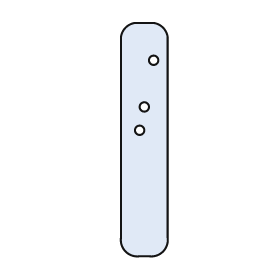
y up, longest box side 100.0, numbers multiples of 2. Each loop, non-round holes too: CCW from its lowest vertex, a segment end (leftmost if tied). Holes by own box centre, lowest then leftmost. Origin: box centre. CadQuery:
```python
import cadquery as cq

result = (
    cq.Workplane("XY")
    .moveTo(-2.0, -50.0)
    .lineTo(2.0, -50.0)
    .threePointArc((8.0, -48.0), (10.0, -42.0))
    .lineTo(10.0, 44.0)
    .threePointArc((8.0, 48.0), (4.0, 50.0))
    .lineTo(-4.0, 50.0)
    .threePointArc((-8.0, 48.0), (-10.0, 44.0))
    .lineTo(-10.0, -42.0)
    .threePointArc((-8.0, -48.0), (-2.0, -50.0))
    .close()
    .moveTo(-2.0, 4.0)
    .circle(2.0)
    .moveTo(0.0, 14.0)
    .circle(2.0)
    .moveTo(4.0, 34.0)
    .circle(2.0)
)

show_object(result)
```